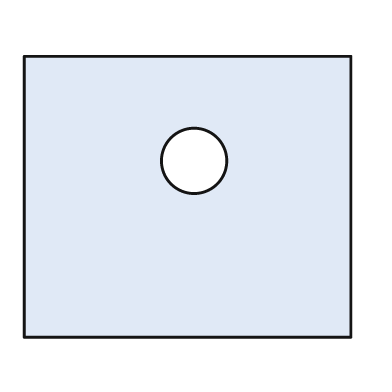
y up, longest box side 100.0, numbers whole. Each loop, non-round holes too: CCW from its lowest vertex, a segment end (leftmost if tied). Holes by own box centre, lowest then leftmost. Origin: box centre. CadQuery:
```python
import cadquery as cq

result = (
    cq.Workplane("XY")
    .moveTo(-50.0, -43.0)
    .lineTo(50.0, -43.0)
    .lineTo(50.0, 43.0)
    .lineTo(-50.0, 43.0)
    .close()
    .moveTo(2.0, 11.0)
    .circle(10.0)
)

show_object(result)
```